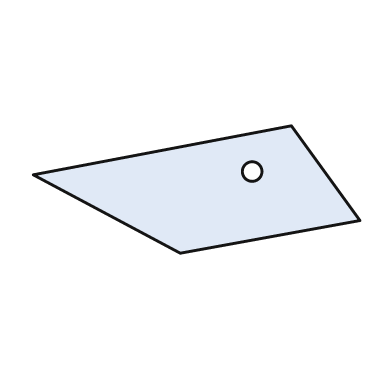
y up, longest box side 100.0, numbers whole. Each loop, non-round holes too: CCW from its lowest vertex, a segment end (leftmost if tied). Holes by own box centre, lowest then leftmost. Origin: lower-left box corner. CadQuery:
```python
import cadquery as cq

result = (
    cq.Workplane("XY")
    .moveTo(45.0, 0.0)
    .lineTo(100.0, 10.0)
    .lineTo(79.0, 39.0)
    .lineTo(0.0, 24.0)
    .close()
    .moveTo(67.0, 25.0)
    .circle(3.0)
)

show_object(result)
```